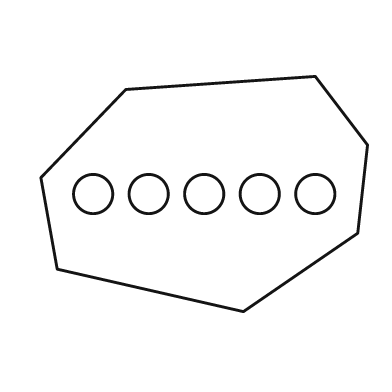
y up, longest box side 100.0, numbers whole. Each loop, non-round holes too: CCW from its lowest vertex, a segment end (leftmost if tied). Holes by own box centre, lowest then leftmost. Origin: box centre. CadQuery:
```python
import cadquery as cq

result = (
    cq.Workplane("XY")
    .moveTo(12.0, -36.0)
    .lineTo(47.0, -12.0)
    .lineTo(50.0, 15.0)
    .lineTo(34.0, 36.0)
    .lineTo(-24.0, 32.0)
    .lineTo(-50.0, 5.0)
    .lineTo(-45.0, -23.0)
    .close()
    .moveTo(-34.0, 0.0)
    .circle(6.0)
    .moveTo(-17.0, 0.0)
    .circle(6.0)
    .moveTo(0.0, 0.0)
    .circle(6.0)
    .moveTo(17.0, 0.0)
    .circle(6.0)
    .moveTo(34.0, 0.0)
    .circle(6.0)
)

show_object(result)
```